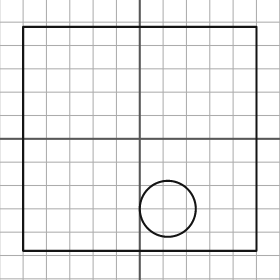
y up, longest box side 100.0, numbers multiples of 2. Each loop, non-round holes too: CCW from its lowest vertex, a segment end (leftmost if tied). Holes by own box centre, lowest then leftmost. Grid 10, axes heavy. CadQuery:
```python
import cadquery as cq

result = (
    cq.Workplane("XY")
    .moveTo(-50.0, -48.0)
    .lineTo(50.0, -48.0)
    .lineTo(50.0, 48.0)
    .lineTo(-50.0, 48.0)
    .close()
    .moveTo(12.0, -30.0)
    .circle(12.0)
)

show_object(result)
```